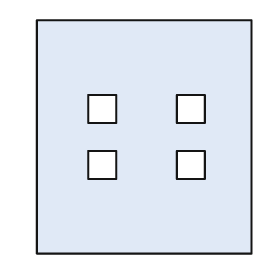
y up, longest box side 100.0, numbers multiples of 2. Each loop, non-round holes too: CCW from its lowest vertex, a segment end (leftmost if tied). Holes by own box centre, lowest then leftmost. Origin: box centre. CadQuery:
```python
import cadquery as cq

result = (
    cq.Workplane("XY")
    .moveTo(-46.0, -50.0)
    .lineTo(46.0, -50.0)
    .lineTo(46.0, 50.0)
    .lineTo(-46.0, 50.0)
    .close()
    .moveTo(-24.0, -18.0)
    .lineTo(-12.0, -18.0)
    .lineTo(-12.0, -6.0)
    .lineTo(-24.0, -6.0)
    .close()
    .moveTo(14.0, -18.0)
    .lineTo(26.0, -18.0)
    .lineTo(26.0, -6.0)
    .lineTo(14.0, -6.0)
    .close()
    .moveTo(-24.0, 6.0)
    .lineTo(-12.0, 6.0)
    .lineTo(-12.0, 18.0)
    .lineTo(-24.0, 18.0)
    .close()
    .moveTo(14.0, 6.0)
    .lineTo(26.0, 6.0)
    .lineTo(26.0, 18.0)
    .lineTo(14.0, 18.0)
    .close()
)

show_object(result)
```